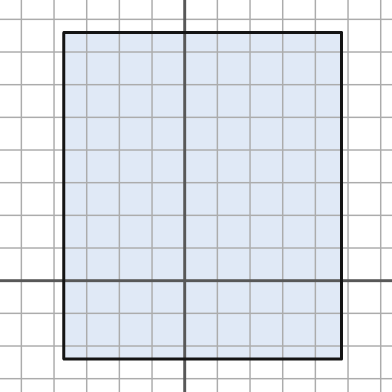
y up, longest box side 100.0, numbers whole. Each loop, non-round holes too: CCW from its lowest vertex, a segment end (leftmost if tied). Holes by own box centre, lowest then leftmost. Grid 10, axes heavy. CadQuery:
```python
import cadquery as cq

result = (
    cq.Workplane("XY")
    .moveTo(-37.0, -24.0)
    .lineTo(48.0, -24.0)
    .lineTo(48.0, 76.0)
    .lineTo(-37.0, 76.0)
    .close()
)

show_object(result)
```